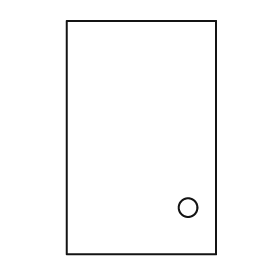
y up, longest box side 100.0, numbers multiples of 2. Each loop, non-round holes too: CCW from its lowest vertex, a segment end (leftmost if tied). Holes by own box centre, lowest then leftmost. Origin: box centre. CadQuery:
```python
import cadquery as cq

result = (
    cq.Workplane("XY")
    .moveTo(-32.0, -50.0)
    .lineTo(32.0, -50.0)
    .lineTo(32.0, 50.0)
    .lineTo(-32.0, 50.0)
    .close()
    .moveTo(20.0, -30.0)
    .circle(4.0)
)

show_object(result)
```